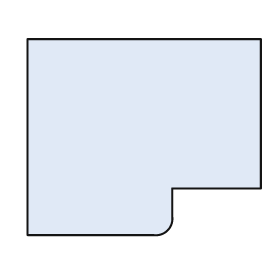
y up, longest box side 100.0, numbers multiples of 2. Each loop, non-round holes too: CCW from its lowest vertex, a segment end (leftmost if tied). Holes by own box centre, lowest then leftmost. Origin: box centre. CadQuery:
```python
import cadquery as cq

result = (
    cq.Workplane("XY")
    .moveTo(-50.0, -42.0)
    .lineTo(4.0, -42.0)
    .threePointArc((10.0, -40.0), (12.0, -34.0))
    .lineTo(12.0, -22.0)
    .lineTo(50.0, -22.0)
    .lineTo(50.0, 42.0)
    .lineTo(-50.0, 42.0)
    .close()
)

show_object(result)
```